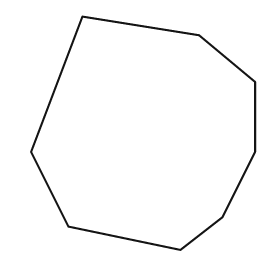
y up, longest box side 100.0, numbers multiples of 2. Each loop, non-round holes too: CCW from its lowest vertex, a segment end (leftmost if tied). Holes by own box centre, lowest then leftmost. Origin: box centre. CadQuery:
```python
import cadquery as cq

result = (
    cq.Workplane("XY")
    .moveTo(16.0, -50.0)
    .lineTo(34.0, -36.0)
    .lineTo(48.0, -8.0)
    .lineTo(48.0, 22.0)
    .lineTo(24.0, 42.0)
    .lineTo(-26.0, 50.0)
    .lineTo(-48.0, -8.0)
    .lineTo(-32.0, -40.0)
    .close()
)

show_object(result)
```